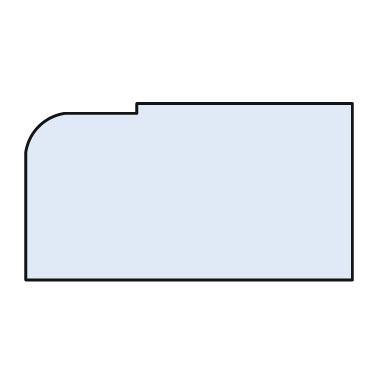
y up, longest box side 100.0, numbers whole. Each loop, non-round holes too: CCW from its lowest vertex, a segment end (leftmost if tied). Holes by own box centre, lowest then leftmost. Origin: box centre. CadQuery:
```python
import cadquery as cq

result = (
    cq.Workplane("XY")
    .moveTo(-50.0, -27.0)
    .lineTo(50.0, -27.0)
    .lineTo(50.0, 27.0)
    .lineTo(-16.0, 27.0)
    .lineTo(-16.0, 24.0)
    .lineTo(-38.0, 24.0)
    .threePointArc((-46.0, 20.0), (-50.0, 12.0))
    .close()
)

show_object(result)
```